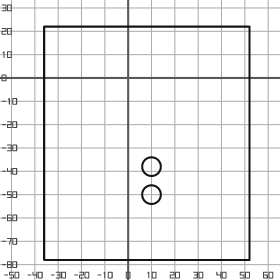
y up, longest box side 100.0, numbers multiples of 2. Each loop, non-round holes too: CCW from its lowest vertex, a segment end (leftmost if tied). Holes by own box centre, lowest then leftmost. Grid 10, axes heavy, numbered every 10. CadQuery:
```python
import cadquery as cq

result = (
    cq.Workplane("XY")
    .moveTo(-36.0, -78.0)
    .lineTo(52.0, -78.0)
    .lineTo(52.0, 22.0)
    .lineTo(-36.0, 22.0)
    .close()
    .moveTo(10.0, -50.0)
    .circle(4.0)
    .moveTo(10.0, -38.0)
    .circle(4.0)
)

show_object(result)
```